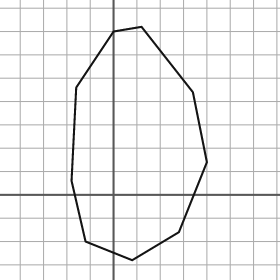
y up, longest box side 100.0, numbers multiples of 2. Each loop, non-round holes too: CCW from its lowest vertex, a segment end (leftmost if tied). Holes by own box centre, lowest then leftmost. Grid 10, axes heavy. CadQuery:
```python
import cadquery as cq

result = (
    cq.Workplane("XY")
    .moveTo(8.0, -28.0)
    .lineTo(28.0, -16.0)
    .lineTo(40.0, 14.0)
    .lineTo(34.0, 44.0)
    .lineTo(12.0, 72.0)
    .lineTo(0.0, 70.0)
    .lineTo(-16.0, 46.0)
    .lineTo(-18.0, 6.0)
    .lineTo(-12.0, -20.0)
    .close()
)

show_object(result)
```